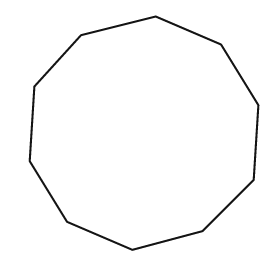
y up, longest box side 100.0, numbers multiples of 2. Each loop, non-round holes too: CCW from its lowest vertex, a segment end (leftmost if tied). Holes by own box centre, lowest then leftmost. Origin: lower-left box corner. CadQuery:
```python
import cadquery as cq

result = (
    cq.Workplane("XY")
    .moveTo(44.0, 0.0)
    .lineTo(74.0, 8.0)
    .lineTo(96.0, 30.0)
    .lineTo(98.0, 62.0)
    .lineTo(82.0, 88.0)
    .lineTo(54.0, 100.0)
    .lineTo(22.0, 92.0)
    .lineTo(2.0, 70.0)
    .lineTo(0.0, 38.0)
    .lineTo(16.0, 12.0)
    .close()
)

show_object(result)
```